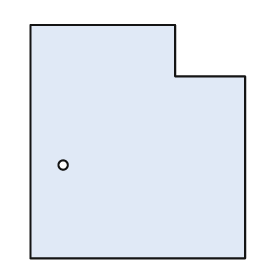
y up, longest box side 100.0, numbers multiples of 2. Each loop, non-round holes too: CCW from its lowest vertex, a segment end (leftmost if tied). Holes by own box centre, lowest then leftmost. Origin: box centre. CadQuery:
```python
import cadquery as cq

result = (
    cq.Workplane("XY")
    .moveTo(-46.0, -50.0)
    .lineTo(46.0, -50.0)
    .lineTo(46.0, 28.0)
    .lineTo(16.0, 28.0)
    .lineTo(16.0, 50.0)
    .lineTo(-46.0, 50.0)
    .close()
    .moveTo(-32.0, -10.0)
    .circle(2.0)
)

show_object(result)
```